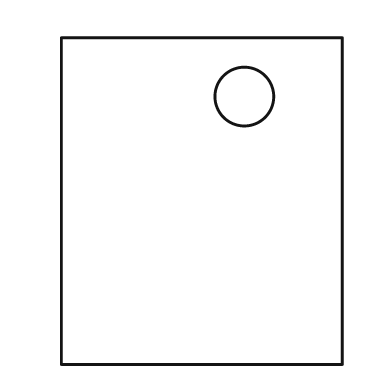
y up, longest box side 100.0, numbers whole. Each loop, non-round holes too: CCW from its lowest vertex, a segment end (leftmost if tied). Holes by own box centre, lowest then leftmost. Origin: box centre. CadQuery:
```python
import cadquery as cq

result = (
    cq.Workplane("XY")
    .moveTo(-43.0, -50.0)
    .lineTo(43.0, -50.0)
    .lineTo(43.0, 50.0)
    .lineTo(-43.0, 50.0)
    .close()
    .moveTo(13.0, 32.0)
    .circle(9.0)
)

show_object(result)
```